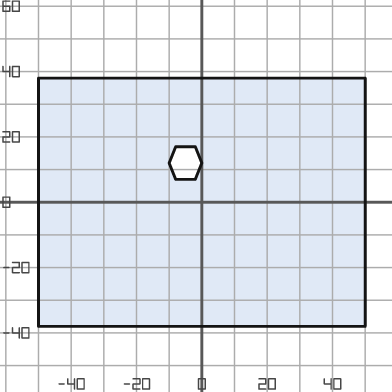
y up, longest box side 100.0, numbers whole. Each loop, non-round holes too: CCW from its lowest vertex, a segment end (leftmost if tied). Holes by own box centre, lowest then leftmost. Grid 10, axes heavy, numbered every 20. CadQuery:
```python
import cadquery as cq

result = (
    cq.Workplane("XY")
    .moveTo(-50.0, -38.0)
    .lineTo(50.0, -38.0)
    .lineTo(50.0, 38.0)
    .lineTo(-50.0, 38.0)
    .close()
    .moveTo(-8.0, 7.0)
    .lineTo(-2.0, 7.0)
    .lineTo(0.0, 12.0)
    .lineTo(-2.0, 17.0)
    .lineTo(-8.0, 17.0)
    .lineTo(-10.0, 12.0)
    .close()
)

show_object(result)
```